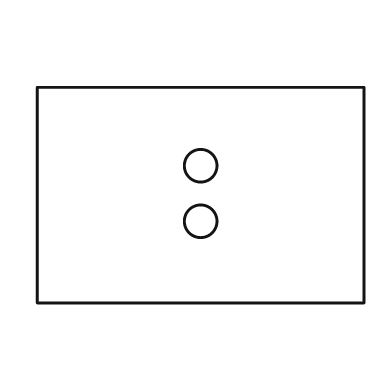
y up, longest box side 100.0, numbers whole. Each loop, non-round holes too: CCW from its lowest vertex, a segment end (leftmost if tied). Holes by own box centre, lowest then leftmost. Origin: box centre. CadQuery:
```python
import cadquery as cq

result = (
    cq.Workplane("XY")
    .moveTo(-50.0, -33.0)
    .lineTo(50.0, -33.0)
    .lineTo(50.0, 33.0)
    .lineTo(-50.0, 33.0)
    .close()
    .moveTo(0.0, -8.0)
    .circle(5.0)
    .moveTo(0.0, 9.0)
    .circle(5.0)
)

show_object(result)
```